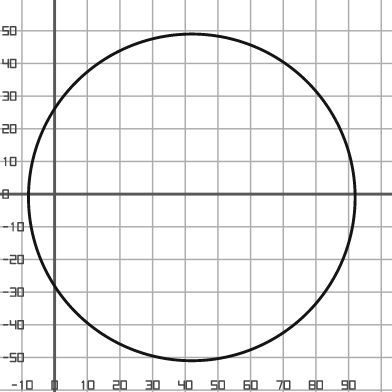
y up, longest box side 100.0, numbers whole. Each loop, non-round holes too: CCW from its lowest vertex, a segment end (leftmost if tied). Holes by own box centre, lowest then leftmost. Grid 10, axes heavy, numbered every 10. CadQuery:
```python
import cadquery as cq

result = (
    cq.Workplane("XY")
    .moveTo(42.0, -1.0)
    .circle(50.0)
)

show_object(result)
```